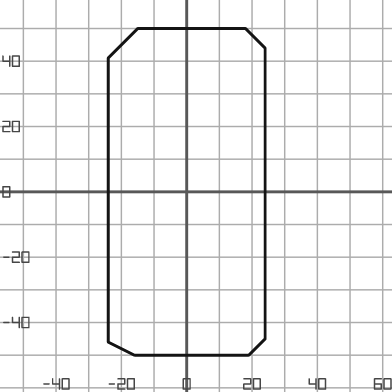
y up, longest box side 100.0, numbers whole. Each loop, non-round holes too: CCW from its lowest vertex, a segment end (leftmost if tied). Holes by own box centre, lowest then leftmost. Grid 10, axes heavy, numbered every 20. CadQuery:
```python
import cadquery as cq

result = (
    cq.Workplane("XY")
    .moveTo(-16.0, -50.0)
    .lineTo(19.0, -50.0)
    .lineTo(24.0, -45.0)
    .lineTo(24.0, 44.0)
    .lineTo(18.0, 50.0)
    .lineTo(-15.0, 50.0)
    .lineTo(-24.0, 41.0)
    .lineTo(-24.0, -46.0)
    .close()
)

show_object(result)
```